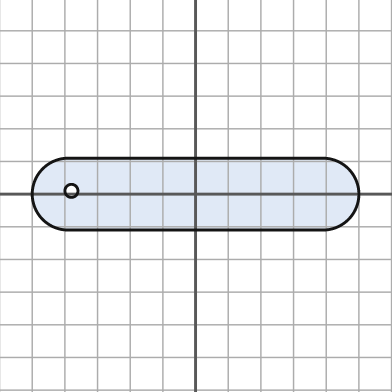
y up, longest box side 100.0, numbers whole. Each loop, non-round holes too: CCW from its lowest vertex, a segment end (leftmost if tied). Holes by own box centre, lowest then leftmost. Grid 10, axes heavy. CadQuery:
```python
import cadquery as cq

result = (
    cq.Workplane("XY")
    .moveTo(-39.0, -11.0)
    .lineTo(39.0, -11.0)
    .threePointArc((50.0, 0.0), (39.0, 11.0))
    .lineTo(-39.0, 11.0)
    .threePointArc((-50.0, 0.0), (-39.0, -11.0))
    .close()
    .moveTo(-38.0, 1.0)
    .circle(2.0)
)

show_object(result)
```